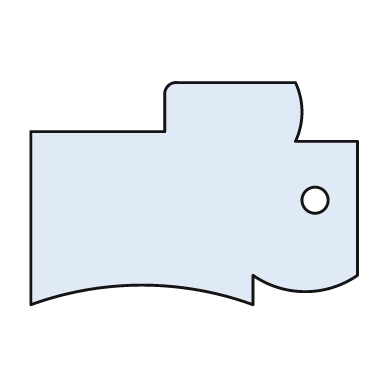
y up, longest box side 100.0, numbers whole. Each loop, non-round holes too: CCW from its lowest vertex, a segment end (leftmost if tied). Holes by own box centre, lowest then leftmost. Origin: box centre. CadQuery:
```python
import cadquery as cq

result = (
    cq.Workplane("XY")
    .moveTo(-50.0, -34.0)
    .threePointArc((-16.0, -28.0), (18.0, -34.0))
    .lineTo(18.0, -25.0)
    .threePointArc((34.0, -30.0), (50.0, -25.0))
    .lineTo(50.0, 16.0)
    .lineTo(31.0, 16.0)
    .threePointArc((33.0, 25.0), (31.0, 34.0))
    .lineTo(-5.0, 34.0)
    .threePointArc((-8.0, 33.0), (-9.0, 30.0))
    .lineTo(-9.0, 19.0)
    .lineTo(-50.0, 19.0)
    .close()
    .moveTo(37.0, -2.0)
    .circle(4.0)
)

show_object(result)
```